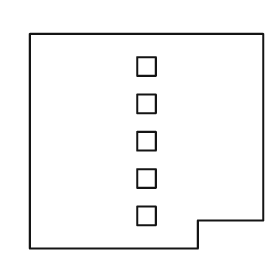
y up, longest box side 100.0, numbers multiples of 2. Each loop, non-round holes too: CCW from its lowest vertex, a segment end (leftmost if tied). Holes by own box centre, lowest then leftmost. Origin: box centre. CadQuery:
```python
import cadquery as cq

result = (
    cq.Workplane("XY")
    .moveTo(-50.0, -46.0)
    .lineTo(22.0, -46.0)
    .lineTo(22.0, -34.0)
    .lineTo(50.0, -34.0)
    .lineTo(50.0, 46.0)
    .lineTo(-50.0, 46.0)
    .close()
    .moveTo(-4.0, -36.0)
    .lineTo(4.0, -36.0)
    .lineTo(4.0, -28.0)
    .lineTo(-4.0, -28.0)
    .close()
    .moveTo(-4.0, -20.0)
    .lineTo(4.0, -20.0)
    .lineTo(4.0, -12.0)
    .lineTo(-4.0, -12.0)
    .close()
    .moveTo(-4.0, -4.0)
    .lineTo(4.0, -4.0)
    .lineTo(4.0, 4.0)
    .lineTo(-4.0, 4.0)
    .close()
    .moveTo(-4.0, 12.0)
    .lineTo(4.0, 12.0)
    .lineTo(4.0, 20.0)
    .lineTo(-4.0, 20.0)
    .close()
    .moveTo(-4.0, 28.0)
    .lineTo(4.0, 28.0)
    .lineTo(4.0, 36.0)
    .lineTo(-4.0, 36.0)
    .close()
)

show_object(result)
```